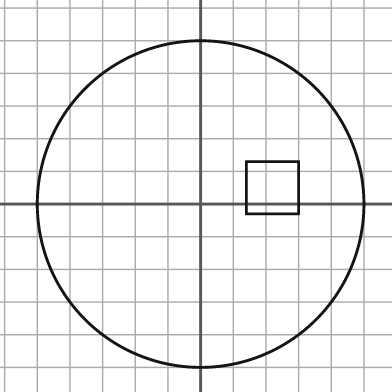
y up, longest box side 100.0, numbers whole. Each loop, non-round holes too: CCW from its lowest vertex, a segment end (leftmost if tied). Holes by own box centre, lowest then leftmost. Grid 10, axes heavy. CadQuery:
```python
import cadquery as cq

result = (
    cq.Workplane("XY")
    .moveTo(0.0, 0.0)
    .circle(50.0)
    .moveTo(14.0, -3.0)
    .lineTo(30.0, -3.0)
    .lineTo(30.0, 13.0)
    .lineTo(14.0, 13.0)
    .close()
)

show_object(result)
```